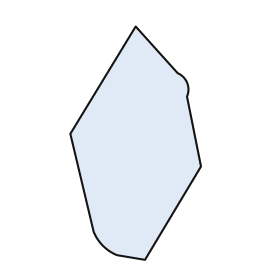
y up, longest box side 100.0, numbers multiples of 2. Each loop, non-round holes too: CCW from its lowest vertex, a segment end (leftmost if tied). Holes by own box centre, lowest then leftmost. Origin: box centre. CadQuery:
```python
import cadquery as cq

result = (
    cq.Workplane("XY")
    .moveTo(4.0, -50.0)
    .lineTo(28.0, -10.0)
    .lineTo(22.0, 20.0)
    .threePointArc((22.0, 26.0), (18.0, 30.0))
    .lineTo(0.0, 50.0)
    .lineTo(-28.0, 4.0)
    .lineTo(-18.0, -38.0)
    .threePointArc((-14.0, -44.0), (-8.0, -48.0))
    .close()
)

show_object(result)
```